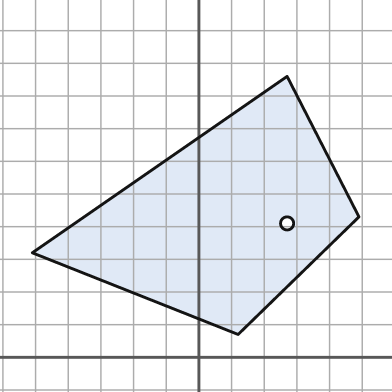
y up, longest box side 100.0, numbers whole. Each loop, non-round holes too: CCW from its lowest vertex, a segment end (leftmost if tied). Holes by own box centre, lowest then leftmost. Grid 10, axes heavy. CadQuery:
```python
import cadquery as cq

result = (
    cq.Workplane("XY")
    .moveTo(12.0, 7.0)
    .lineTo(49.0, 43.0)
    .lineTo(27.0, 86.0)
    .lineTo(-51.0, 32.0)
    .close()
    .moveTo(27.0, 41.0)
    .circle(2.0)
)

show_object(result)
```